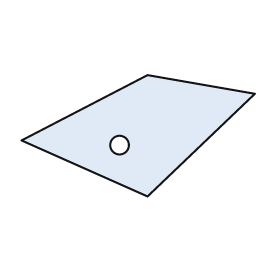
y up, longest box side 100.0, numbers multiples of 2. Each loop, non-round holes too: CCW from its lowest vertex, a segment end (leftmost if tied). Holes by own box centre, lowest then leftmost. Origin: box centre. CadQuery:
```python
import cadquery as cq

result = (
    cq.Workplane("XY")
    .moveTo(4.0, -26.0)
    .lineTo(50.0, 18.0)
    .lineTo(4.0, 26.0)
    .lineTo(-50.0, -2.0)
    .close()
    .moveTo(-8.0, -4.0)
    .circle(4.0)
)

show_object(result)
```